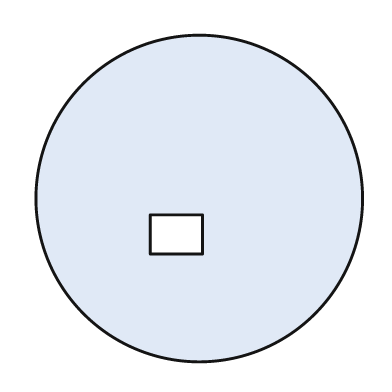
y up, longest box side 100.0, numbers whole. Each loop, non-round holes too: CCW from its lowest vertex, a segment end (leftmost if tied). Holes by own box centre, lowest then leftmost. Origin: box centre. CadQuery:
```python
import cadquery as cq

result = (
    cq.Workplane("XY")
    .moveTo(0.0, 0.0)
    .circle(50.0)
    .moveTo(-15.0, -17.0)
    .lineTo(1.0, -17.0)
    .lineTo(1.0, -5.0)
    .lineTo(-15.0, -5.0)
    .close()
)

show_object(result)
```